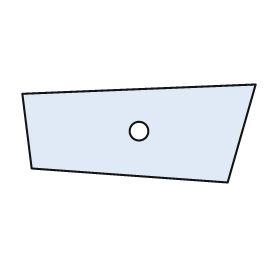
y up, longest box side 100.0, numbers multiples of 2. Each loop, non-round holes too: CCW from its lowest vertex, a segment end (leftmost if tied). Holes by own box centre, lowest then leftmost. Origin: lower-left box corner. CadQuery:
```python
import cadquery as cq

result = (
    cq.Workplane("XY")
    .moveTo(88.0, 0.0)
    .lineTo(100.0, 42.0)
    .lineTo(0.0, 38.0)
    .lineTo(4.0, 6.0)
    .close()
    .moveTo(50.0, 22.0)
    .circle(4.0)
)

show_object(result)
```